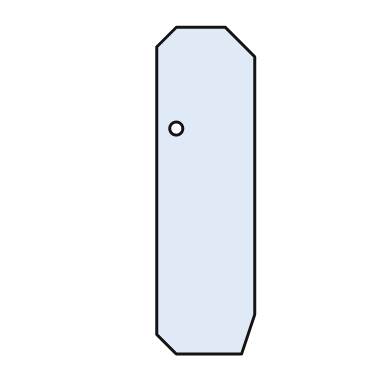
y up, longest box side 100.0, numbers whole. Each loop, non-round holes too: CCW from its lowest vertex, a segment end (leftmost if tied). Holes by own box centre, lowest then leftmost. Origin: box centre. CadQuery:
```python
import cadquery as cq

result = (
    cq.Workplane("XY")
    .moveTo(-9.0, -50.0)
    .lineTo(11.0, -50.0)
    .lineTo(15.0, -38.0)
    .lineTo(15.0, 41.0)
    .lineTo(6.0, 50.0)
    .lineTo(-9.0, 50.0)
    .lineTo(-15.0, 44.0)
    .lineTo(-15.0, -44.0)
    .close()
    .moveTo(-9.0, 19.0)
    .circle(2.0)
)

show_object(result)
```